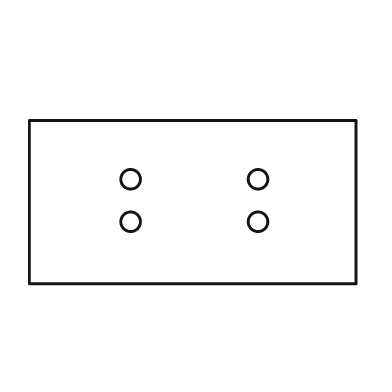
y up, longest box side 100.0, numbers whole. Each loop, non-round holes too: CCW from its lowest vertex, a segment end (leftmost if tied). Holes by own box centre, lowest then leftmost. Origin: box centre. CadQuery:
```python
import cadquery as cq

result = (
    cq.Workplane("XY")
    .moveTo(-50.0, -25.0)
    .lineTo(50.0, -25.0)
    .lineTo(50.0, 25.0)
    .lineTo(-50.0, 25.0)
    .close()
    .moveTo(-19.0, -6.0)
    .circle(3.0)
    .moveTo(20.0, -6.0)
    .circle(3.0)
    .moveTo(-19.0, 7.0)
    .circle(3.0)
    .moveTo(20.0, 7.0)
    .circle(3.0)
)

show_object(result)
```